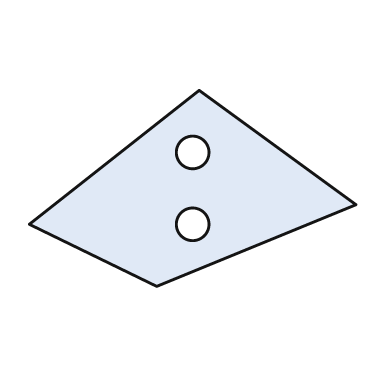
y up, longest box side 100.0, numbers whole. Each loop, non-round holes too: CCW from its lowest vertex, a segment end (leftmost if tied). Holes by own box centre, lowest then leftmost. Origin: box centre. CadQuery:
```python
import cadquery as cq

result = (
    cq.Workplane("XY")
    .moveTo(-11.0, -30.0)
    .lineTo(50.0, -5.0)
    .lineTo(2.0, 30.0)
    .lineTo(-50.0, -11.0)
    .close()
    .moveTo(0.0, -11.0)
    .circle(5.0)
    .moveTo(0.0, 11.0)
    .circle(5.0)
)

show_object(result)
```